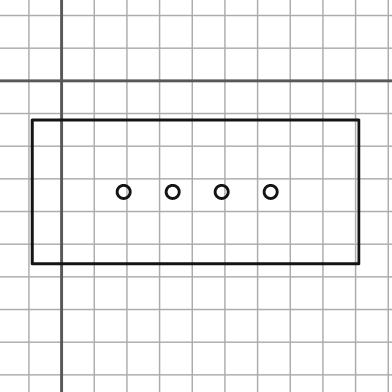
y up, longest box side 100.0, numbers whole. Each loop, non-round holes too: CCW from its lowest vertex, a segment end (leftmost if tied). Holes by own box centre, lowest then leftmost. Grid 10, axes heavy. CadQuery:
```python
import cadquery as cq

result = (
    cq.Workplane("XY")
    .moveTo(-9.0, -56.0)
    .lineTo(91.0, -56.0)
    .lineTo(91.0, -12.0)
    .lineTo(-9.0, -12.0)
    .close()
    .moveTo(19.0, -34.0)
    .circle(2.0)
    .moveTo(34.0, -34.0)
    .circle(2.0)
    .moveTo(49.0, -34.0)
    .circle(2.0)
    .moveTo(64.0, -34.0)
    .circle(2.0)
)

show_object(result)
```